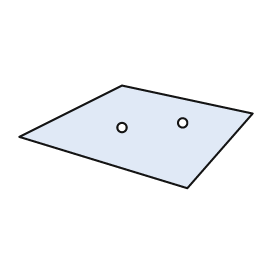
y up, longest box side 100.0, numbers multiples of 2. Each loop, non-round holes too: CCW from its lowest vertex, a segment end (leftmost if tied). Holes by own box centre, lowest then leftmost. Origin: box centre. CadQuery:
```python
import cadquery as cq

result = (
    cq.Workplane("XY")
    .moveTo(22.0, -22.0)
    .lineTo(50.0, 10.0)
    .lineTo(-6.0, 22.0)
    .lineTo(-50.0, 0.0)
    .close()
    .moveTo(-6.0, 4.0)
    .circle(2.0)
    .moveTo(20.0, 6.0)
    .circle(2.0)
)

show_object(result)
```